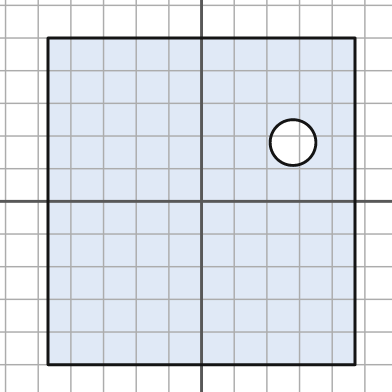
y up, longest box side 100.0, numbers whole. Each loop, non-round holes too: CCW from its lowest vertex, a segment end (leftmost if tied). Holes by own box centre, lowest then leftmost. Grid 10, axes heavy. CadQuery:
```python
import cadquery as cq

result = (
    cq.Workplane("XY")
    .moveTo(-47.0, -50.0)
    .lineTo(47.0, -50.0)
    .lineTo(47.0, 50.0)
    .lineTo(-47.0, 50.0)
    .close()
    .moveTo(28.0, 18.0)
    .circle(7.0)
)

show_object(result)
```